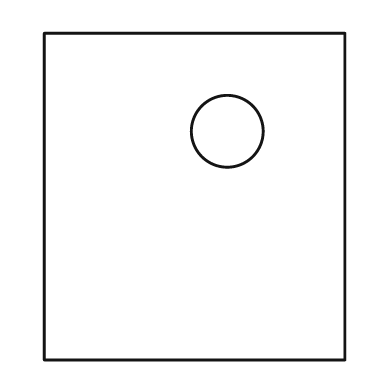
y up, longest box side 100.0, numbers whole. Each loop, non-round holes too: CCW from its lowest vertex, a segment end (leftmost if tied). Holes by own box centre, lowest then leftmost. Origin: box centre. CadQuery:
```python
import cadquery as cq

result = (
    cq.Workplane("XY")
    .moveTo(-46.0, -50.0)
    .lineTo(46.0, -50.0)
    .lineTo(46.0, 50.0)
    .lineTo(-46.0, 50.0)
    .close()
    .moveTo(10.0, 20.0)
    .circle(11.0)
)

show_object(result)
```